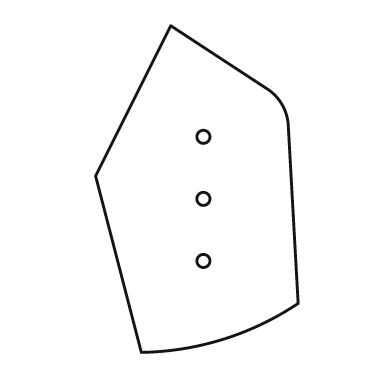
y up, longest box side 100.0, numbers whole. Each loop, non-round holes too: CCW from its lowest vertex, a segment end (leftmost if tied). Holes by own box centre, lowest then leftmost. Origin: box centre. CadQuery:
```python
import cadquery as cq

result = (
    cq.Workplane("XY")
    .moveTo(-17.0, -50.0)
    .threePointArc((8.0, -46.0), (31.0, -35.0))
    .lineTo(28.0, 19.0)
    .threePointArc((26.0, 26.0), (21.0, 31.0))
    .lineTo(-8.0, 50.0)
    .lineTo(-31.0, 4.0)
    .close()
    .moveTo(2.0, -22.0)
    .circle(2.0)
    .moveTo(2.0, -3.0)
    .circle(2.0)
    .moveTo(2.0, 16.0)
    .circle(2.0)
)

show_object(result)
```